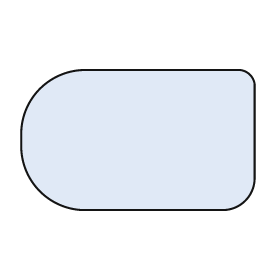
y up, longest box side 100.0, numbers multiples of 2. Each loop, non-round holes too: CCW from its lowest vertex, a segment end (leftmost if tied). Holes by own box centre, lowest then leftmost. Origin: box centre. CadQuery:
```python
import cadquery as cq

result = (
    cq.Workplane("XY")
    .moveTo(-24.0, -30.0)
    .lineTo(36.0, -30.0)
    .threePointArc((46.0, -26.0), (50.0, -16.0))
    .lineTo(50.0, 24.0)
    .threePointArc((48.0, 28.0), (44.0, 30.0))
    .lineTo(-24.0, 30.0)
    .threePointArc((-42.0, 22.0), (-50.0, 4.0))
    .lineTo(-50.0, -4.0)
    .threePointArc((-42.0, -22.0), (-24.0, -30.0))
    .close()
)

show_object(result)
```